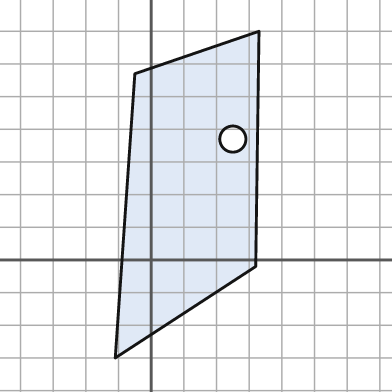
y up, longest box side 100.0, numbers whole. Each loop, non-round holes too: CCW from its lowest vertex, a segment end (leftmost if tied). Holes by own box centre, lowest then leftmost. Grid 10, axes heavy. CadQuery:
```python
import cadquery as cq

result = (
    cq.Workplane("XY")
    .moveTo(-11.0, -30.0)
    .lineTo(32.0, -2.0)
    .lineTo(33.0, 70.0)
    .lineTo(-5.0, 57.0)
    .close()
    .moveTo(25.0, 37.0)
    .circle(4.0)
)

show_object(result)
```